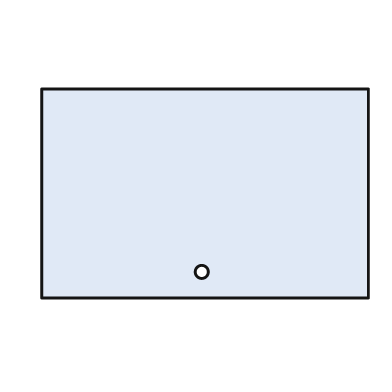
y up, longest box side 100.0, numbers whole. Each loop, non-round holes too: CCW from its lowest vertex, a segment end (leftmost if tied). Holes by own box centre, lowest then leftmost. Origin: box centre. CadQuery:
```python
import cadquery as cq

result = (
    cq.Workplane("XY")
    .moveTo(-50.0, -32.0)
    .lineTo(50.0, -32.0)
    .lineTo(50.0, 32.0)
    .lineTo(-50.0, 32.0)
    .close()
    .moveTo(-1.0, -24.0)
    .circle(2.0)
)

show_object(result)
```